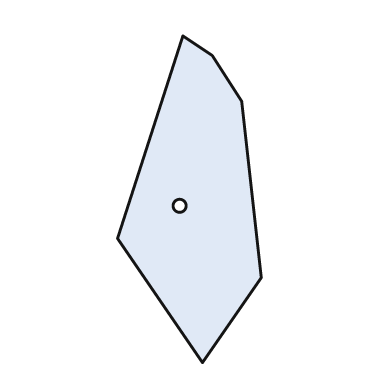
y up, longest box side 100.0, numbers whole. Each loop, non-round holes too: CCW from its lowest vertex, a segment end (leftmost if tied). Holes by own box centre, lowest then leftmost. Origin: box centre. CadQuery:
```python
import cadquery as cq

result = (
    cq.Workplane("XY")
    .moveTo(4.0, -50.0)
    .lineTo(22.0, -24.0)
    .lineTo(16.0, 30.0)
    .lineTo(7.0, 44.0)
    .lineTo(-2.0, 50.0)
    .lineTo(-22.0, -12.0)
    .close()
    .moveTo(-3.0, -2.0)
    .circle(2.0)
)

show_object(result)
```